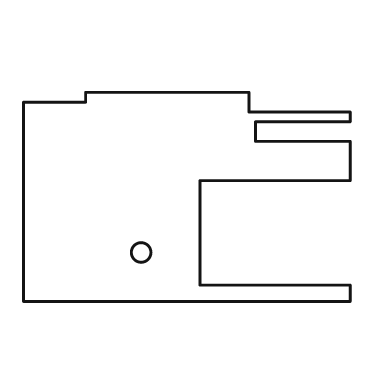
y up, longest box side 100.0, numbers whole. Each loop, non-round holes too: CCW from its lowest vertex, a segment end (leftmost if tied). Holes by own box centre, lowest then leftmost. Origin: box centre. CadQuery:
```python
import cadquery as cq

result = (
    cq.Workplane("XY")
    .moveTo(-50.0, -32.0)
    .lineTo(50.0, -32.0)
    .lineTo(50.0, -27.0)
    .lineTo(4.0, -27.0)
    .lineTo(4.0, 5.0)
    .lineTo(50.0, 5.0)
    .lineTo(50.0, 17.0)
    .lineTo(21.0, 17.0)
    .lineTo(21.0, 23.0)
    .lineTo(50.0, 23.0)
    .lineTo(50.0, 26.0)
    .lineTo(19.0, 26.0)
    .lineTo(19.0, 32.0)
    .lineTo(-31.0, 32.0)
    .lineTo(-31.0, 29.0)
    .lineTo(-50.0, 29.0)
    .close()
    .moveTo(-14.0, -17.0)
    .circle(3.0)
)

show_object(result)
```